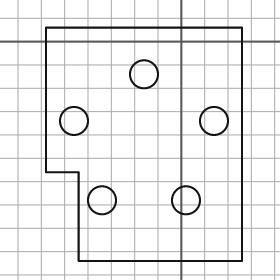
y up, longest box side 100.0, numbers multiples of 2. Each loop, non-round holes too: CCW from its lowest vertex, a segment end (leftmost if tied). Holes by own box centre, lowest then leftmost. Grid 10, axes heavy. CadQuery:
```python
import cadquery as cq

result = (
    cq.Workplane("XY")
    .moveTo(-44.0, -94.0)
    .lineTo(26.0, -94.0)
    .lineTo(26.0, 6.0)
    .lineTo(-58.0, 6.0)
    .lineTo(-58.0, -56.0)
    .lineTo(-44.0, -56.0)
    .close()
    .moveTo(-34.0, -68.0)
    .circle(6.0)
    .moveTo(2.0, -68.0)
    .circle(6.0)
    .moveTo(-46.0, -34.0)
    .circle(6.0)
    .moveTo(14.0, -34.0)
    .circle(6.0)
    .moveTo(-16.0, -14.0)
    .circle(6.0)
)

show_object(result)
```